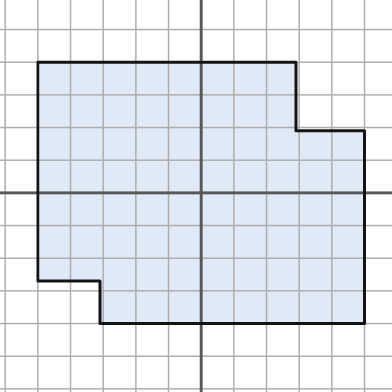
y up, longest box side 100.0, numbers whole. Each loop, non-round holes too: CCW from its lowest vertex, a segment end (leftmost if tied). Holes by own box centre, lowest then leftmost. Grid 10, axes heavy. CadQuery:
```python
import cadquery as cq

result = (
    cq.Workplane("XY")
    .moveTo(-31.0, -40.0)
    .lineTo(50.0, -40.0)
    .lineTo(50.0, 19.0)
    .lineTo(29.0, 19.0)
    .lineTo(29.0, 40.0)
    .lineTo(-50.0, 40.0)
    .lineTo(-50.0, -27.0)
    .lineTo(-31.0, -27.0)
    .close()
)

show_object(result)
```